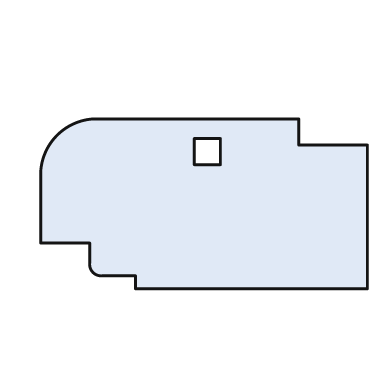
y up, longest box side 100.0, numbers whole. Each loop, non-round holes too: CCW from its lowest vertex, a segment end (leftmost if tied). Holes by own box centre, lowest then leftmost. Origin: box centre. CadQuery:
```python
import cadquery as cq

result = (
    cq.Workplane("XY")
    .moveTo(-21.0, -26.0)
    .lineTo(50.0, -26.0)
    .lineTo(50.0, 18.0)
    .lineTo(29.0, 18.0)
    .lineTo(29.0, 26.0)
    .lineTo(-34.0, 26.0)
    .threePointArc((-45.0, 21.0), (-50.0, 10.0))
    .lineTo(-50.0, -12.0)
    .lineTo(-35.0, -12.0)
    .lineTo(-35.0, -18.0)
    .threePointArc((-34.0, -21.0), (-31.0, -22.0))
    .lineTo(-21.0, -22.0)
    .close()
    .moveTo(-3.0, 12.0)
    .lineTo(5.0, 12.0)
    .lineTo(5.0, 20.0)
    .lineTo(-3.0, 20.0)
    .close()
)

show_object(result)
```